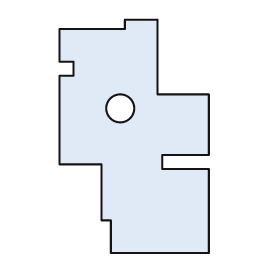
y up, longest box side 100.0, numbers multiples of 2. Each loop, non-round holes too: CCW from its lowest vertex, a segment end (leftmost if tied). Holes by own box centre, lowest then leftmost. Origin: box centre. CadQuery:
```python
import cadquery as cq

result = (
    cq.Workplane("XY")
    .moveTo(-10.0, -50.0)
    .lineTo(32.0, -50.0)
    .lineTo(32.0, -14.0)
    .lineTo(12.0, -14.0)
    .lineTo(12.0, -8.0)
    .lineTo(32.0, -8.0)
    .lineTo(32.0, 18.0)
    .lineTo(10.0, 18.0)
    .lineTo(10.0, 50.0)
    .lineTo(-4.0, 50.0)
    .lineTo(-4.0, 46.0)
    .lineTo(-32.0, 46.0)
    .lineTo(-32.0, 32.0)
    .lineTo(-26.0, 32.0)
    .lineTo(-26.0, 26.0)
    .lineTo(-32.0, 26.0)
    .lineTo(-32.0, -12.0)
    .lineTo(-14.0, -12.0)
    .lineTo(-14.0, -36.0)
    .lineTo(-10.0, -36.0)
    .close()
    .moveTo(-6.0, 12.0)
    .circle(6.0)
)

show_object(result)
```